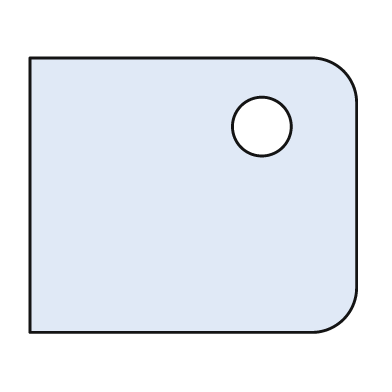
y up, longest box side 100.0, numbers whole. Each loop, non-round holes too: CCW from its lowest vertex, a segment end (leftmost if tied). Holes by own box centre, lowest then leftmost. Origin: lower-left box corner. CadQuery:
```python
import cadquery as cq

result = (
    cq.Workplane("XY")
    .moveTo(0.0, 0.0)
    .lineTo(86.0, 0.0)
    .threePointArc((96.0, 4.0), (100.0, 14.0))
    .lineTo(100.0, 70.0)
    .threePointArc((96.0, 80.0), (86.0, 84.0))
    .lineTo(0.0, 84.0)
    .close()
    .moveTo(71.0, 63.0)
    .circle(9.0)
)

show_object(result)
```